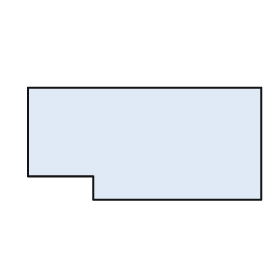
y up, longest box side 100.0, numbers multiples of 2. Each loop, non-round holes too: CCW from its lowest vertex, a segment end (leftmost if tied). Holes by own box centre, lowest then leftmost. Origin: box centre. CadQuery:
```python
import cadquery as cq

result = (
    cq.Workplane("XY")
    .moveTo(-22.0, -24.0)
    .lineTo(50.0, -24.0)
    .lineTo(50.0, 24.0)
    .lineTo(-50.0, 24.0)
    .lineTo(-50.0, -14.0)
    .lineTo(-22.0, -14.0)
    .close()
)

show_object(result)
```